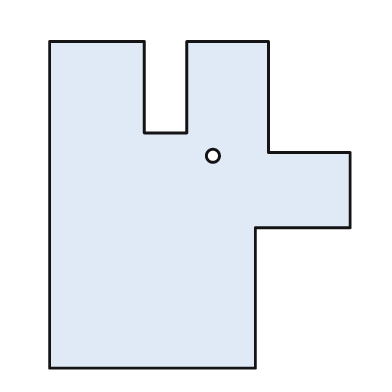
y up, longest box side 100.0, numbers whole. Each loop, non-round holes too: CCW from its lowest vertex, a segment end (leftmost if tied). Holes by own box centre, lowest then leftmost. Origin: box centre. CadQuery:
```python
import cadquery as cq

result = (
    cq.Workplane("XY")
    .moveTo(-46.0, -50.0)
    .lineTo(17.0, -50.0)
    .lineTo(17.0, -7.0)
    .lineTo(46.0, -7.0)
    .lineTo(46.0, 16.0)
    .lineTo(21.0, 16.0)
    .lineTo(21.0, 50.0)
    .lineTo(-4.0, 50.0)
    .lineTo(-4.0, 22.0)
    .lineTo(-17.0, 22.0)
    .lineTo(-17.0, 50.0)
    .lineTo(-46.0, 50.0)
    .close()
    .moveTo(4.0, 15.0)
    .circle(2.0)
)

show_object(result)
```